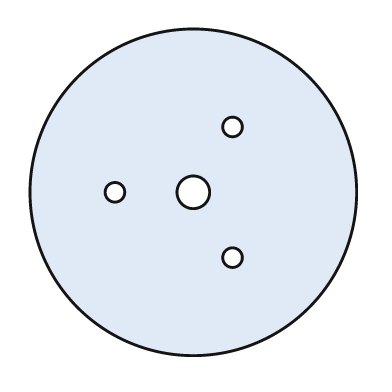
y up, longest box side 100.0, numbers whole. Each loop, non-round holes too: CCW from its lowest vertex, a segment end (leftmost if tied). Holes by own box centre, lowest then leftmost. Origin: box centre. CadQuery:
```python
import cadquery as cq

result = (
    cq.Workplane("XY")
    .moveTo(0.0, 0.0)
    .circle(50.0)
    .moveTo(12.0, -20.0)
    .circle(3.0)
    .moveTo(-24.0, 0.0)
    .circle(3.0)
    .moveTo(0.0, 0.0)
    .circle(5.0)
    .moveTo(12.0, 20.0)
    .circle(3.0)
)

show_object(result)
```